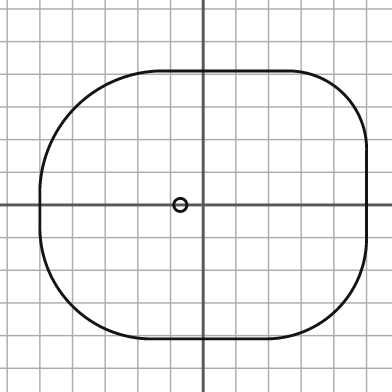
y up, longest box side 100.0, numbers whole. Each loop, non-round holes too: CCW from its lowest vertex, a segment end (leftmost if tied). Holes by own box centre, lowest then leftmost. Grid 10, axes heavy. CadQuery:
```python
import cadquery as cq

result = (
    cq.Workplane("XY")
    .moveTo(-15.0, -41.0)
    .lineTo(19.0, -41.0)
    .threePointArc((41.0, -32.0), (50.0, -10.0))
    .lineTo(50.0, 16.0)
    .threePointArc((43.0, 34.0), (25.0, 41.0))
    .lineTo(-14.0, 41.0)
    .threePointArc((-39.0, 30.0), (-50.0, 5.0))
    .lineTo(-50.0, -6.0)
    .threePointArc((-40.0, -31.0), (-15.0, -41.0))
    .close()
    .moveTo(-7.0, 0.0)
    .circle(2.0)
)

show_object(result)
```